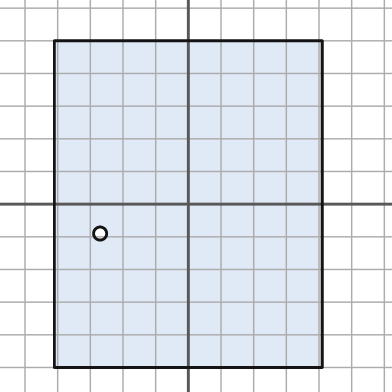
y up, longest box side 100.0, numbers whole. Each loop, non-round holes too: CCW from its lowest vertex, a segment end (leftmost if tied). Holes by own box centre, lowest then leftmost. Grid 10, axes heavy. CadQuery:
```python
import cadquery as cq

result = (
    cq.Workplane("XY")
    .moveTo(-41.0, -50.0)
    .lineTo(41.0, -50.0)
    .lineTo(41.0, 50.0)
    .lineTo(-41.0, 50.0)
    .close()
    .moveTo(-27.0, -9.0)
    .circle(2.0)
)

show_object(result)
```